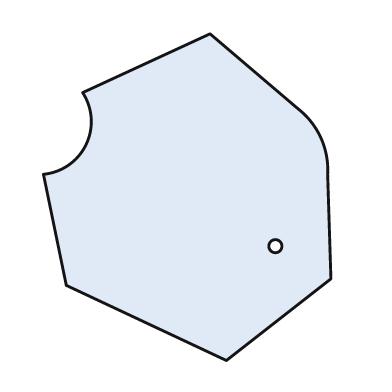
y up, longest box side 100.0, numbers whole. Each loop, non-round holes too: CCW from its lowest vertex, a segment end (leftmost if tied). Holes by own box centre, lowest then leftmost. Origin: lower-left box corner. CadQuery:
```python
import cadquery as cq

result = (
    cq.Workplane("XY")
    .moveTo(56.0, 0.0)
    .lineTo(88.0, 25.0)
    .lineTo(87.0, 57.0)
    .threePointArc((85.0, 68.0), (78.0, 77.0))
    .lineTo(51.0, 100.0)
    .lineTo(12.0, 82.0)
    .threePointArc((13.0, 66.0), (0.0, 57.0))
    .lineTo(7.0, 23.0)
    .close()
    .moveTo(71.0, 35.0)
    .circle(2.0)
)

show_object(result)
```